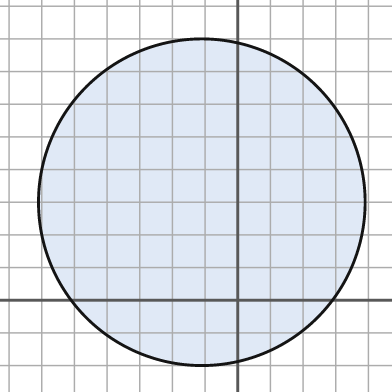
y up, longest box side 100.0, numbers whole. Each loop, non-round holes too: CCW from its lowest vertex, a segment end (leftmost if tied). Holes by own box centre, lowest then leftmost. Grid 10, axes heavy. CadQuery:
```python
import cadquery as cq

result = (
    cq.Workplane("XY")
    .moveTo(-11.0, 30.0)
    .circle(50.0)
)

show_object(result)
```